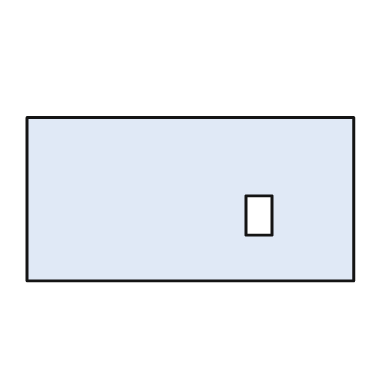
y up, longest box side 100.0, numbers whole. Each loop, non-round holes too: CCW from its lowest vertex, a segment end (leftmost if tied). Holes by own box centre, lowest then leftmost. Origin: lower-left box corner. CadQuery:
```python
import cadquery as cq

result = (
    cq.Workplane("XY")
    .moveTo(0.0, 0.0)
    .lineTo(100.0, 0.0)
    .lineTo(100.0, 50.0)
    .lineTo(0.0, 50.0)
    .close()
    .moveTo(67.0, 14.0)
    .lineTo(75.0, 14.0)
    .lineTo(75.0, 26.0)
    .lineTo(67.0, 26.0)
    .close()
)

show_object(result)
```